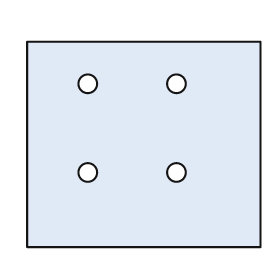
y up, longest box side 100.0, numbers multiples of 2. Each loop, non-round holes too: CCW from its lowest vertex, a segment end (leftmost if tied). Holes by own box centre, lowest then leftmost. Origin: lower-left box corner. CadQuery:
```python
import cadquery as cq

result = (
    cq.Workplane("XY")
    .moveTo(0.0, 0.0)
    .lineTo(100.0, 0.0)
    .lineTo(100.0, 88.0)
    .lineTo(0.0, 88.0)
    .close()
    .moveTo(26.0, 32.0)
    .circle(4.0)
    .moveTo(64.0, 32.0)
    .circle(4.0)
    .moveTo(26.0, 70.0)
    .circle(4.0)
    .moveTo(64.0, 70.0)
    .circle(4.0)
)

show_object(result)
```